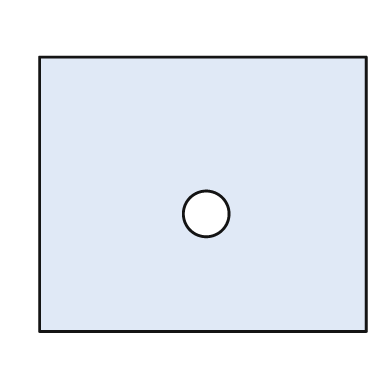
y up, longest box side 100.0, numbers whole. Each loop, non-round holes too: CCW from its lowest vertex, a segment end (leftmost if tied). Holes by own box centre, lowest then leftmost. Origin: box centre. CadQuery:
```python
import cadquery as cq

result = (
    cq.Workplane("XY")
    .moveTo(-50.0, -42.0)
    .lineTo(50.0, -42.0)
    .lineTo(50.0, 42.0)
    .lineTo(-50.0, 42.0)
    .close()
    .moveTo(1.0, -6.0)
    .circle(7.0)
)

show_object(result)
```